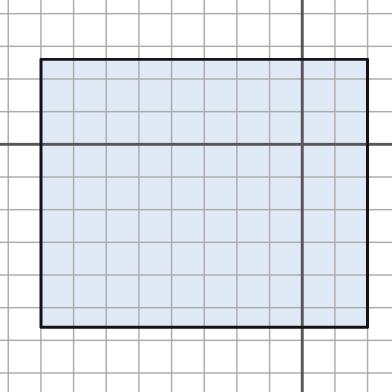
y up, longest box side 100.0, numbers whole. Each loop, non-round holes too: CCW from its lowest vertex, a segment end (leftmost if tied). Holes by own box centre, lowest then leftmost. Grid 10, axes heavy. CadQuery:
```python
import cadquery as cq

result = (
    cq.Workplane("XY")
    .moveTo(-80.0, -56.0)
    .lineTo(20.0, -56.0)
    .lineTo(20.0, 26.0)
    .lineTo(-80.0, 26.0)
    .close()
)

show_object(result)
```